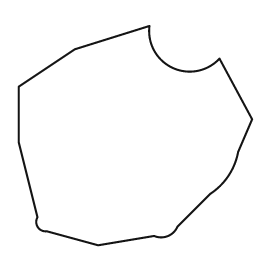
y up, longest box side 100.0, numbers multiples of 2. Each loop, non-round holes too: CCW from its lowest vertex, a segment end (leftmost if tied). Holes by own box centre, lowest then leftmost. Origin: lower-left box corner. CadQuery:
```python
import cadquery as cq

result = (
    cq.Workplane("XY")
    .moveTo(34.0, 0.0)
    .lineTo(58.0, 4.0)
    .threePointArc((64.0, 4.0), (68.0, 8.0))
    .lineTo(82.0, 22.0)
    .threePointArc((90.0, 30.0), (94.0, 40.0))
    .lineTo(100.0, 54.0)
    .lineTo(86.0, 80.0)
    .threePointArc((66.0, 76.0), (56.0, 94.0))
    .lineTo(24.0, 84.0)
    .lineTo(0.0, 68.0)
    .lineTo(0.0, 44.0)
    .lineTo(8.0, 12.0)
    .threePointArc((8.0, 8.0), (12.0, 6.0))
    .close()
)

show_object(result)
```